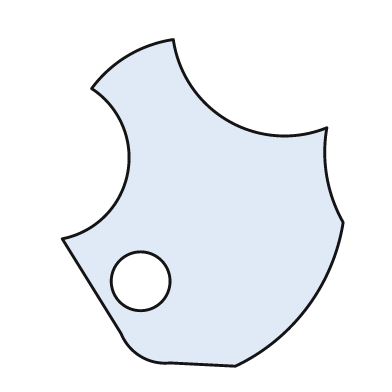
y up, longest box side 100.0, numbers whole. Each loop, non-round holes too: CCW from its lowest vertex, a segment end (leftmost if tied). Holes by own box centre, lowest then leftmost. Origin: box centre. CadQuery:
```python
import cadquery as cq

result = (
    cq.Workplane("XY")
    .moveTo(10.0, -50.0)
    .threePointArc((32.0, -32.0), (43.0, -6.0))
    .threePointArc((38.0, 8.0), (38.0, 23.0))
    .threePointArc((8.0, 25.0), (-9.0, 50.0))
    .threePointArc((-23.0, 45.0), (-34.0, 35.0))
    .threePointArc((-23.0, 9.0), (-43.0, -11.0))
    .lineTo(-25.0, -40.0)
    .threePointArc((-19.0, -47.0), (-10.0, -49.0))
    .close()
    .moveTo(-19.0, -24.0)
    .circle(9.0)
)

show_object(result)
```